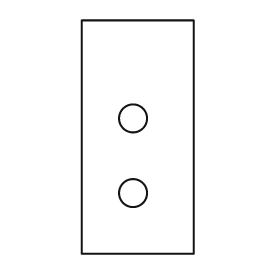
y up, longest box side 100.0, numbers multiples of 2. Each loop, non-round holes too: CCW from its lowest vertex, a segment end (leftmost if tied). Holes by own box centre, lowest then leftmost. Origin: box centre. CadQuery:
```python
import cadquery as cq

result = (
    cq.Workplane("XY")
    .moveTo(-24.0, -50.0)
    .lineTo(24.0, -50.0)
    .lineTo(24.0, 50.0)
    .lineTo(-24.0, 50.0)
    .close()
    .moveTo(-2.0, -24.0)
    .circle(6.0)
    .moveTo(-2.0, 8.0)
    .circle(6.0)
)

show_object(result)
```